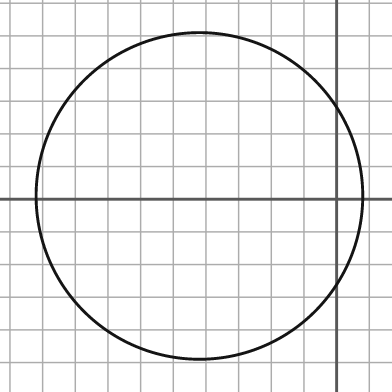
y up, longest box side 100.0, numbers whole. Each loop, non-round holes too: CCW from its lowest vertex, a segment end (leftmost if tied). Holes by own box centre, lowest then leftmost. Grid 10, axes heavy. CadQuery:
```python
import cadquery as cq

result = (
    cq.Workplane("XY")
    .moveTo(-42.0, 1.0)
    .circle(50.0)
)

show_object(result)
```